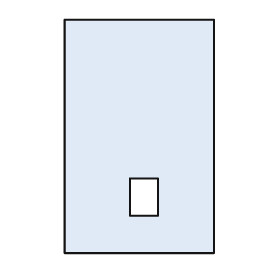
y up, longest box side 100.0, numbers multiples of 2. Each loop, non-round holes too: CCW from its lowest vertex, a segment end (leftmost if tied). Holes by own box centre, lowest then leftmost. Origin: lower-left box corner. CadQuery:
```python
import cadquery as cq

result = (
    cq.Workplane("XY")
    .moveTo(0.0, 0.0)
    .lineTo(64.0, 0.0)
    .lineTo(64.0, 100.0)
    .lineTo(0.0, 100.0)
    .close()
    .moveTo(28.0, 16.0)
    .lineTo(40.0, 16.0)
    .lineTo(40.0, 32.0)
    .lineTo(28.0, 32.0)
    .close()
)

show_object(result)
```